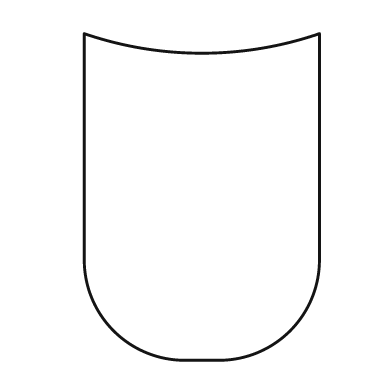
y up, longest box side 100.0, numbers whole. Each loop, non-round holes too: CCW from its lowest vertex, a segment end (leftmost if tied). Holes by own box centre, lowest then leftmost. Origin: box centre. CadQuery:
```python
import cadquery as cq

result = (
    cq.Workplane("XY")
    .moveTo(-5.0, -50.0)
    .lineTo(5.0, -50.0)
    .threePointArc((27.0, -41.0), (36.0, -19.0))
    .lineTo(36.0, 50.0)
    .threePointArc((0.0, 44.0), (-36.0, 50.0))
    .lineTo(-36.0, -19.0)
    .threePointArc((-27.0, -41.0), (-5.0, -50.0))
    .close()
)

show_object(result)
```